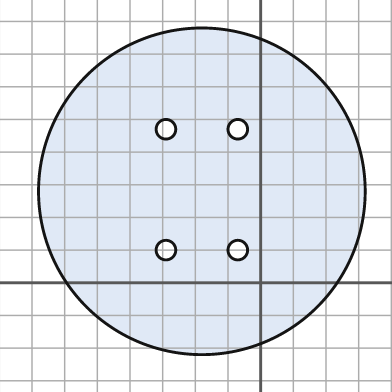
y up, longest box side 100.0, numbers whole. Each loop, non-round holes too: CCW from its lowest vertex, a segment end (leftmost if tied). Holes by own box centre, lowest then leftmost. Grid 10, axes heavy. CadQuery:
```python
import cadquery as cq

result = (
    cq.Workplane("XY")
    .moveTo(-18.0, 28.0)
    .circle(50.0)
    .moveTo(-29.0, 10.0)
    .circle(3.0)
    .moveTo(-7.0, 10.0)
    .circle(3.0)
    .moveTo(-29.0, 47.0)
    .circle(3.0)
    .moveTo(-7.0, 47.0)
    .circle(3.0)
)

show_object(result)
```